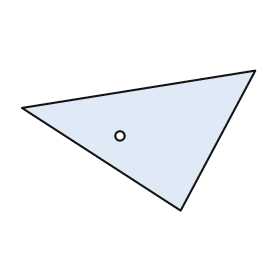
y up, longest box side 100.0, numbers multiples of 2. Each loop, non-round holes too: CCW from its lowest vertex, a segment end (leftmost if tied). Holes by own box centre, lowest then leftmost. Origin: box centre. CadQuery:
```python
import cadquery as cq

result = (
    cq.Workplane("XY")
    .moveTo(18.0, -30.0)
    .lineTo(50.0, 30.0)
    .lineTo(-50.0, 14.0)
    .close()
    .moveTo(-8.0, 2.0)
    .circle(2.0)
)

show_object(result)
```